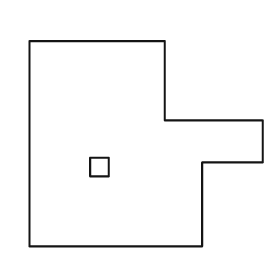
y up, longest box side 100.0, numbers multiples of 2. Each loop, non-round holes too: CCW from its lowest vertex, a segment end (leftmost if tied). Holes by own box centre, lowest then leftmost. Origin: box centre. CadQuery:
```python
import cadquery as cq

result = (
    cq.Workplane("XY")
    .moveTo(-50.0, -44.0)
    .lineTo(24.0, -44.0)
    .lineTo(24.0, -8.0)
    .lineTo(50.0, -8.0)
    .lineTo(50.0, 10.0)
    .lineTo(8.0, 10.0)
    .lineTo(8.0, 44.0)
    .lineTo(-50.0, 44.0)
    .close()
    .moveTo(-24.0, -14.0)
    .lineTo(-16.0, -14.0)
    .lineTo(-16.0, -6.0)
    .lineTo(-24.0, -6.0)
    .close()
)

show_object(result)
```